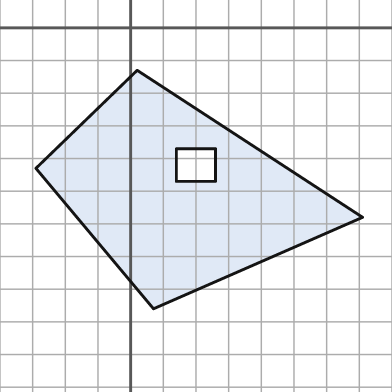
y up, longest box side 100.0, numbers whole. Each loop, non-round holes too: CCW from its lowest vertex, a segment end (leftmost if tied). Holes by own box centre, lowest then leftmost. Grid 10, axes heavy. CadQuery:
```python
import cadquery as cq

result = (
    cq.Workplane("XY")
    .moveTo(7.0, -86.0)
    .lineTo(71.0, -58.0)
    .lineTo(2.0, -13.0)
    .lineTo(-29.0, -43.0)
    .close()
    .moveTo(14.0, -47.0)
    .lineTo(26.0, -47.0)
    .lineTo(26.0, -37.0)
    .lineTo(14.0, -37.0)
    .close()
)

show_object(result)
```